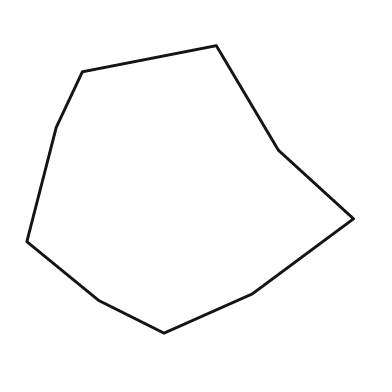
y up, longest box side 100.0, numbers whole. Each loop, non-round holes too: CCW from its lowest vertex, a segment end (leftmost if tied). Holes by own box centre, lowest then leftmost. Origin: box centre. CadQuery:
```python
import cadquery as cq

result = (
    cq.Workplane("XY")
    .moveTo(-8.0, -44.0)
    .lineTo(19.0, -32.0)
    .lineTo(50.0, -9.0)
    .lineTo(27.0, 12.0)
    .lineTo(8.0, 44.0)
    .lineTo(-33.0, 36.0)
    .lineTo(-41.0, 19.0)
    .lineTo(-50.0, -16.0)
    .lineTo(-28.0, -34.0)
    .close()
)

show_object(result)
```